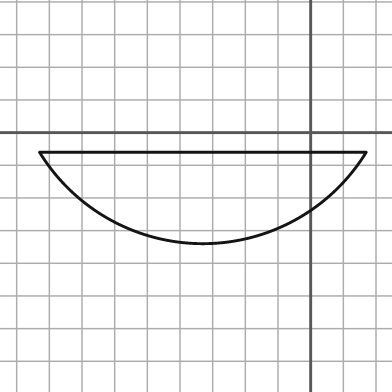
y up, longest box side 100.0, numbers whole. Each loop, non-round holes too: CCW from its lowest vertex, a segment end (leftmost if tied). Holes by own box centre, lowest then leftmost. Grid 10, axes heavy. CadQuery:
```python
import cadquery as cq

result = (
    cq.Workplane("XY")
    .moveTo(-83.0, -6.0)
    .threePointArc((-33.0, -34.0), (17.0, -6.0))
    .close()
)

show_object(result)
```